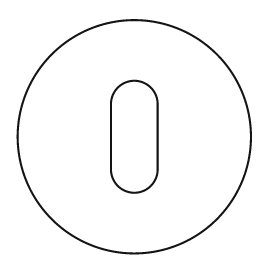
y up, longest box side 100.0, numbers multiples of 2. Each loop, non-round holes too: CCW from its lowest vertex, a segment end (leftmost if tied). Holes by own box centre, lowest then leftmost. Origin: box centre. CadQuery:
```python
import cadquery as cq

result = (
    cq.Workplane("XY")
    .moveTo(0.0, 0.0)
    .circle(50.0)
    .moveTo(-10.0, -14.0)
    .threePointArc((0.0, -24.0), (10.0, -14.0))
    .lineTo(10.0, 14.0)
    .threePointArc((0.0, 24.0), (-10.0, 14.0))
    .close()
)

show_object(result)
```